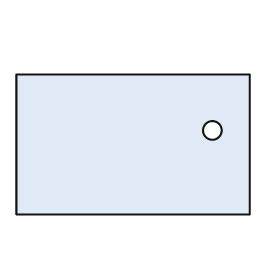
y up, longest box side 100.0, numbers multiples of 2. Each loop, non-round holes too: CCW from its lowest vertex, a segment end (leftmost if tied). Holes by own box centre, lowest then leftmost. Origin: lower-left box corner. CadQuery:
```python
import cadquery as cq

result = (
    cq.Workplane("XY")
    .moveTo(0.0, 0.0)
    .lineTo(100.0, 0.0)
    .lineTo(100.0, 60.0)
    .lineTo(0.0, 60.0)
    .close()
    .moveTo(84.0, 36.0)
    .circle(4.0)
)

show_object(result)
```